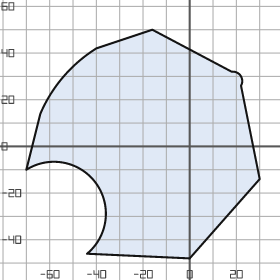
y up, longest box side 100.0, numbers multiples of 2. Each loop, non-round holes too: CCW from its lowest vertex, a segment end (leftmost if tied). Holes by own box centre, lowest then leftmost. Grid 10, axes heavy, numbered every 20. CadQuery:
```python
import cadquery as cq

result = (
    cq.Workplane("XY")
    .moveTo(0.0, -48.0)
    .lineTo(30.0, -14.0)
    .lineTo(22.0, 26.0)
    .threePointArc((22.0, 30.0), (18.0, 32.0))
    .lineTo(-16.0, 50.0)
    .lineTo(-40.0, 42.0)
    .threePointArc((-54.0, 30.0), (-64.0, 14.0))
    .lineTo(-70.0, -10.0)
    .threePointArc((-40.0, -16.0), (-44.0, -46.0))
    .close()
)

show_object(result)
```